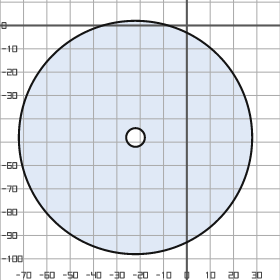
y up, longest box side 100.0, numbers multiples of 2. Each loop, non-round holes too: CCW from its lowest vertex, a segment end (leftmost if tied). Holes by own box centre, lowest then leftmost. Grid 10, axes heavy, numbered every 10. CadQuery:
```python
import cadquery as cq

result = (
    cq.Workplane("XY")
    .moveTo(-22.0, -48.0)
    .circle(50.0)
    .moveTo(-22.0, -48.0)
    .circle(4.0)
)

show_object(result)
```